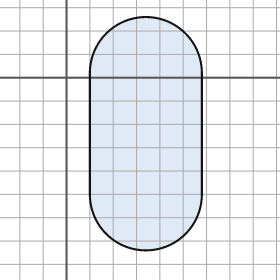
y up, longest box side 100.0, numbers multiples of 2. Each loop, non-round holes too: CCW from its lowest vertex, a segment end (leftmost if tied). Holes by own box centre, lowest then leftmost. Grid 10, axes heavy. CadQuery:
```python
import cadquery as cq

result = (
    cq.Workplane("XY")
    .moveTo(10.0, -50.0)
    .threePointArc((34.0, -74.0), (58.0, -50.0))
    .lineTo(58.0, 2.0)
    .threePointArc((34.0, 26.0), (10.0, 2.0))
    .close()
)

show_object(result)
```